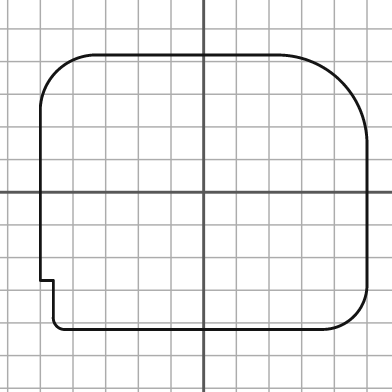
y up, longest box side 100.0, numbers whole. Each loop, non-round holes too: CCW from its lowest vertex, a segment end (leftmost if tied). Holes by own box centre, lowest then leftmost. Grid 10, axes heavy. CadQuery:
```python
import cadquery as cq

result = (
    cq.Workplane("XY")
    .moveTo(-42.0, -42.0)
    .lineTo(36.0, -42.0)
    .threePointArc((46.0, -38.0), (50.0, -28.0))
    .lineTo(50.0, 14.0)
    .threePointArc((42.0, 34.0), (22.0, 42.0))
    .lineTo(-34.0, 42.0)
    .threePointArc((-45.0, 37.0), (-50.0, 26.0))
    .lineTo(-50.0, -27.0)
    .lineTo(-46.0, -27.0)
    .lineTo(-46.0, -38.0)
    .threePointArc((-45.0, -41.0), (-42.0, -42.0))
    .close()
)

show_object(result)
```